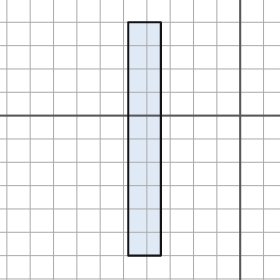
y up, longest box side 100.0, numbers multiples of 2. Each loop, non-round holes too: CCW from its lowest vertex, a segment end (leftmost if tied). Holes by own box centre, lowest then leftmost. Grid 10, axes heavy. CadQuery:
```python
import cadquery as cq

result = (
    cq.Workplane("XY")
    .moveTo(-48.0, -60.0)
    .lineTo(-34.0, -60.0)
    .lineTo(-34.0, 40.0)
    .lineTo(-48.0, 40.0)
    .close()
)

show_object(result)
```